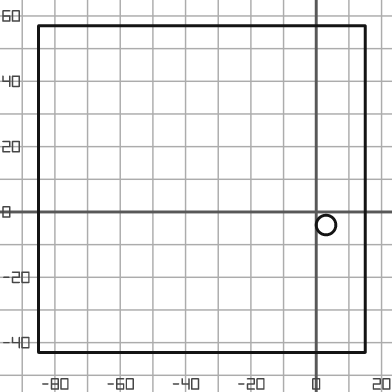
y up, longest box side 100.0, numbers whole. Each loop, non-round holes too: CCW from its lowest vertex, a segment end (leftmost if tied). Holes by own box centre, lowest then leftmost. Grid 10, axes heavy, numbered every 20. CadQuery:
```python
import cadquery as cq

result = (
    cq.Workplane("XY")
    .moveTo(-85.0, -43.0)
    .lineTo(15.0, -43.0)
    .lineTo(15.0, 57.0)
    .lineTo(-85.0, 57.0)
    .close()
    .moveTo(3.0, -4.0)
    .circle(3.0)
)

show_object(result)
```